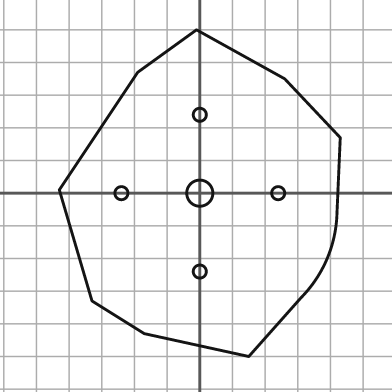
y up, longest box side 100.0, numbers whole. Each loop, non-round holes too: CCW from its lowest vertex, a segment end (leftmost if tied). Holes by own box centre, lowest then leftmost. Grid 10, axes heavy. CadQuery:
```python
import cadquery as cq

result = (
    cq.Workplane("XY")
    .moveTo(15.0, -50.0)
    .lineTo(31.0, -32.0)
    .threePointArc((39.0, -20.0), (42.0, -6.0))
    .lineTo(43.0, 17.0)
    .lineTo(26.0, 35.0)
    .lineTo(-1.0, 50.0)
    .lineTo(-19.0, 37.0)
    .lineTo(-43.0, 1.0)
    .lineTo(-33.0, -33.0)
    .lineTo(-17.0, -43.0)
    .close()
    .moveTo(0.0, -24.0)
    .circle(2.0)
    .moveTo(-24.0, 0.0)
    .circle(2.0)
    .moveTo(0.0, 0.0)
    .circle(4.0)
    .moveTo(24.0, 0.0)
    .circle(2.0)
    .moveTo(0.0, 24.0)
    .circle(2.0)
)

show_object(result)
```